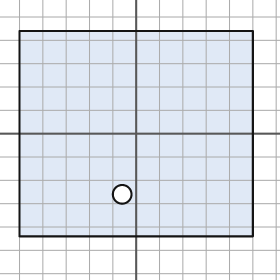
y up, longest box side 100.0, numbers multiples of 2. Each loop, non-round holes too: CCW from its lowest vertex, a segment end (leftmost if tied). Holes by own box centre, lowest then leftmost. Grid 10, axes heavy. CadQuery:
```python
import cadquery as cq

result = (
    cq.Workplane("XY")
    .moveTo(-50.0, -44.0)
    .lineTo(50.0, -44.0)
    .lineTo(50.0, 44.0)
    .lineTo(-50.0, 44.0)
    .close()
    .moveTo(-6.0, -26.0)
    .circle(4.0)
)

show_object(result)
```